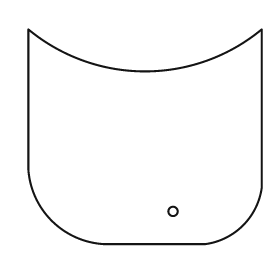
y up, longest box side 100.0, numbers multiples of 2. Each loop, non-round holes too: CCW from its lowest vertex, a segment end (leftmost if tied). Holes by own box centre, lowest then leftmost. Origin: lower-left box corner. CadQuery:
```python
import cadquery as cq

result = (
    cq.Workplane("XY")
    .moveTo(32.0, 0.0)
    .lineTo(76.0, 0.0)
    .threePointArc((92.0, 8.0), (100.0, 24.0))
    .lineTo(100.0, 92.0)
    .threePointArc((50.0, 74.0), (0.0, 92.0))
    .lineTo(0.0, 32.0)
    .threePointArc((10.0, 10.0), (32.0, 0.0))
    .close()
    .moveTo(62.0, 14.0)
    .circle(2.0)
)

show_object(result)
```